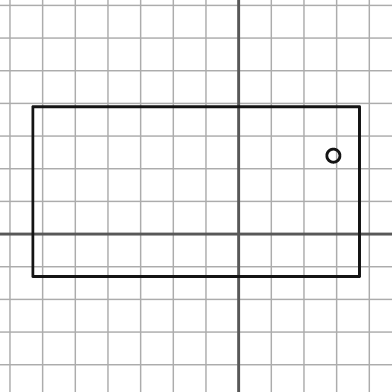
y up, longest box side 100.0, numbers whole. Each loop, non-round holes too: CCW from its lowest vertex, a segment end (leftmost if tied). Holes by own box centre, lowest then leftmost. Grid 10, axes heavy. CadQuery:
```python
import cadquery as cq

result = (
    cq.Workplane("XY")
    .moveTo(-63.0, -13.0)
    .lineTo(37.0, -13.0)
    .lineTo(37.0, 39.0)
    .lineTo(-63.0, 39.0)
    .close()
    .moveTo(29.0, 24.0)
    .circle(2.0)
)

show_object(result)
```